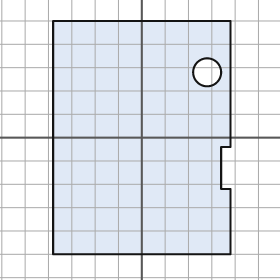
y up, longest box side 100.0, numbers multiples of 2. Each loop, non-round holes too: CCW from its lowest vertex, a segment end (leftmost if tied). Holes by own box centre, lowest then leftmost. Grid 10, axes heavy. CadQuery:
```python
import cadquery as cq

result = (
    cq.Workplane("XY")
    .moveTo(-38.0, -50.0)
    .lineTo(38.0, -50.0)
    .lineTo(38.0, -22.0)
    .lineTo(34.0, -22.0)
    .lineTo(34.0, -4.0)
    .lineTo(38.0, -4.0)
    .lineTo(38.0, 50.0)
    .lineTo(-38.0, 50.0)
    .close()
    .moveTo(28.0, 28.0)
    .circle(6.0)
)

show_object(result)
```